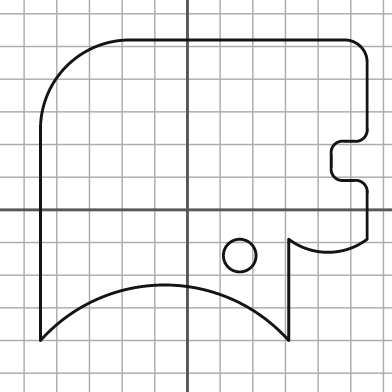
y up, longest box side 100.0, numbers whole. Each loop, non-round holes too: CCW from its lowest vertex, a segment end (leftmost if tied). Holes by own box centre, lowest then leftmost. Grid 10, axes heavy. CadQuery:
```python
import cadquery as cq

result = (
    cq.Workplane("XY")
    .moveTo(-45.0, -40.0)
    .threePointArc((-7.0, -23.0), (31.0, -40.0))
    .lineTo(31.0, -9.0)
    .threePointArc((43.0, -13.0), (55.0, -9.0))
    .lineTo(55.0, 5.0)
    .threePointArc((54.0, 8.0), (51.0, 9.0))
    .lineTo(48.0, 9.0)
    .threePointArc((45.0, 10.0), (44.0, 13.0))
    .lineTo(44.0, 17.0)
    .threePointArc((45.0, 20.0), (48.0, 21.0))
    .lineTo(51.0, 21.0)
    .threePointArc((54.0, 22.0), (55.0, 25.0))
    .lineTo(55.0, 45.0)
    .threePointArc((53.0, 50.0), (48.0, 52.0))
    .lineTo(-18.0, 52.0)
    .threePointArc((-37.0, 44.0), (-45.0, 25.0))
    .close()
    .moveTo(16.0, -14.0)
    .circle(5.0)
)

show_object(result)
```